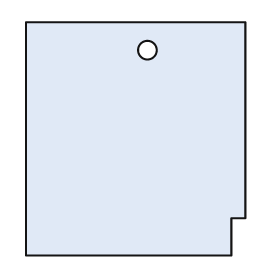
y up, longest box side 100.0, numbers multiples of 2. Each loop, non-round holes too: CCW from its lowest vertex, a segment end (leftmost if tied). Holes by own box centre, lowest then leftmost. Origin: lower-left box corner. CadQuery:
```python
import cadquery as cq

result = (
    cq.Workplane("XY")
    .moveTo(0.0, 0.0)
    .lineTo(88.0, 0.0)
    .lineTo(88.0, 16.0)
    .lineTo(94.0, 16.0)
    .lineTo(94.0, 100.0)
    .lineTo(0.0, 100.0)
    .close()
    .moveTo(52.0, 88.0)
    .circle(4.0)
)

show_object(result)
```